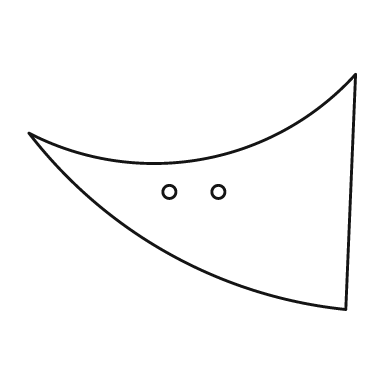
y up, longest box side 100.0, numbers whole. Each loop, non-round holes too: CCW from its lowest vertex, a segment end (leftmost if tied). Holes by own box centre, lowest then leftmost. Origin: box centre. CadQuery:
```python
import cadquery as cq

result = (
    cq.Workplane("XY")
    .moveTo(47.0, -36.0)
    .lineTo(50.0, 36.0)
    .threePointArc((3.0, 10.0), (-50.0, 18.0))
    .threePointArc((-7.0, -19.0), (47.0, -36.0))
    .close()
    .moveTo(-7.0, 0.0)
    .circle(2.0)
    .moveTo(8.0, 0.0)
    .circle(2.0)
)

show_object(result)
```